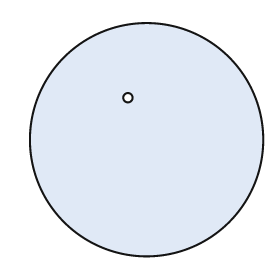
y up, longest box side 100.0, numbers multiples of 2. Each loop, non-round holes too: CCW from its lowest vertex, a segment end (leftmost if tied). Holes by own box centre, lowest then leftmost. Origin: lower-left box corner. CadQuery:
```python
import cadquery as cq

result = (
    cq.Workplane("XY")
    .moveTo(50.0, 50.0)
    .circle(50.0)
    .moveTo(42.0, 68.0)
    .circle(2.0)
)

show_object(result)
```